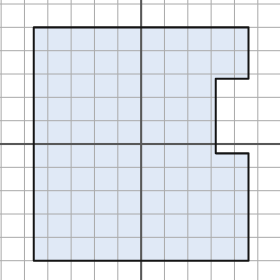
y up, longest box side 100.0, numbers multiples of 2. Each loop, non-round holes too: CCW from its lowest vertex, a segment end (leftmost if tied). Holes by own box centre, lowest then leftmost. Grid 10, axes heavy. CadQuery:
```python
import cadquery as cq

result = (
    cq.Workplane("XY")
    .moveTo(-46.0, -50.0)
    .lineTo(46.0, -50.0)
    .lineTo(46.0, -4.0)
    .lineTo(32.0, -4.0)
    .lineTo(32.0, 28.0)
    .lineTo(46.0, 28.0)
    .lineTo(46.0, 50.0)
    .lineTo(-46.0, 50.0)
    .close()
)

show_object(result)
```